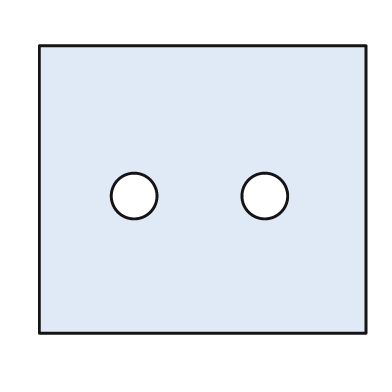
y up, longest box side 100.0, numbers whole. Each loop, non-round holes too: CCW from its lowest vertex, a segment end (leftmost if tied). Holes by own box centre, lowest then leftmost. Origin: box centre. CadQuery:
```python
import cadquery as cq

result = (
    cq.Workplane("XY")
    .moveTo(-50.0, -44.0)
    .lineTo(50.0, -44.0)
    .lineTo(50.0, 44.0)
    .lineTo(-50.0, 44.0)
    .close()
    .moveTo(-21.0, -2.0)
    .circle(7.0)
    .moveTo(19.0, -2.0)
    .circle(7.0)
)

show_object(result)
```